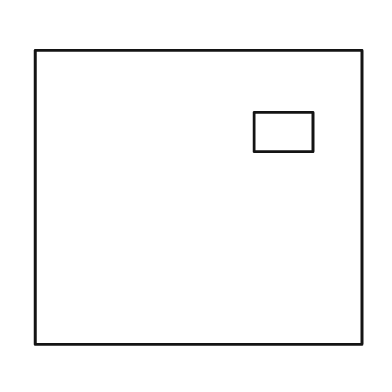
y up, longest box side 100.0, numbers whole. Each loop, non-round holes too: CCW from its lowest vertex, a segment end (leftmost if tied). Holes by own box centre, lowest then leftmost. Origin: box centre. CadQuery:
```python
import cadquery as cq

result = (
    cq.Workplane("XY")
    .moveTo(-50.0, -45.0)
    .lineTo(50.0, -45.0)
    .lineTo(50.0, 45.0)
    .lineTo(-50.0, 45.0)
    .close()
    .moveTo(17.0, 14.0)
    .lineTo(35.0, 14.0)
    .lineTo(35.0, 26.0)
    .lineTo(17.0, 26.0)
    .close()
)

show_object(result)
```